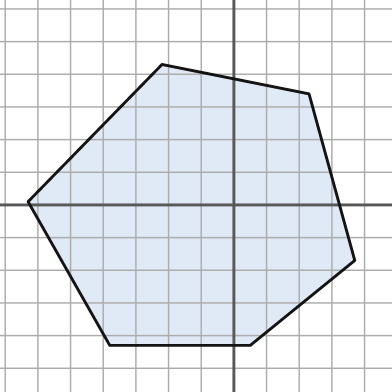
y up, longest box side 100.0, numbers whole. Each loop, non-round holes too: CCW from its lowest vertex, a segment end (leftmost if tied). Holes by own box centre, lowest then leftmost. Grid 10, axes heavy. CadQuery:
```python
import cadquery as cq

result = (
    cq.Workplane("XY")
    .moveTo(-38.0, -43.0)
    .lineTo(5.0, -43.0)
    .lineTo(37.0, -17.0)
    .lineTo(23.0, 34.0)
    .lineTo(-22.0, 43.0)
    .lineTo(-63.0, 1.0)
    .close()
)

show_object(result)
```